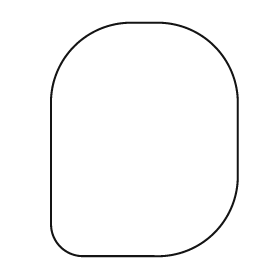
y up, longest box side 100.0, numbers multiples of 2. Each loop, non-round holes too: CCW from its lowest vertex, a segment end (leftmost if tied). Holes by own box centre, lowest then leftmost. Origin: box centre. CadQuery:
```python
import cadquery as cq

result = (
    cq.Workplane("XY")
    .moveTo(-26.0, -50.0)
    .lineTo(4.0, -50.0)
    .threePointArc((30.0, -40.0), (40.0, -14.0))
    .lineTo(40.0, 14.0)
    .threePointArc((30.0, 40.0), (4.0, 50.0))
    .lineTo(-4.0, 50.0)
    .threePointArc((-30.0, 40.0), (-40.0, 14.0))
    .lineTo(-40.0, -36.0)
    .threePointArc((-36.0, -46.0), (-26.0, -50.0))
    .close()
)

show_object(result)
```